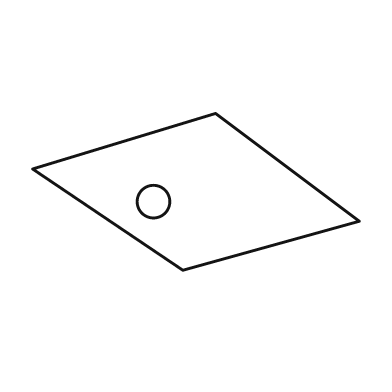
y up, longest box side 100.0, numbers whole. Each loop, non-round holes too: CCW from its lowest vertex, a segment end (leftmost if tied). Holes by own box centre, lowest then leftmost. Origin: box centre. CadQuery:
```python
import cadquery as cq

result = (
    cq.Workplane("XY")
    .moveTo(-4.0, -24.0)
    .lineTo(50.0, -9.0)
    .lineTo(6.0, 24.0)
    .lineTo(-50.0, 7.0)
    .close()
    .moveTo(-13.0, -3.0)
    .circle(5.0)
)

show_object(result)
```